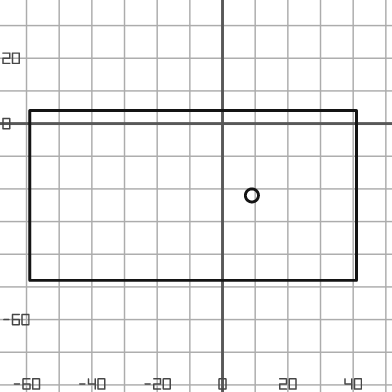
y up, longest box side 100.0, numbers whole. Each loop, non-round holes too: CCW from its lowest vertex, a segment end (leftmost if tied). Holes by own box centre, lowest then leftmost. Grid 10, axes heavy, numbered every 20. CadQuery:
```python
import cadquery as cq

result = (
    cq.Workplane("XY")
    .moveTo(-59.0, -48.0)
    .lineTo(41.0, -48.0)
    .lineTo(41.0, 4.0)
    .lineTo(-59.0, 4.0)
    .close()
    .moveTo(9.0, -22.0)
    .circle(2.0)
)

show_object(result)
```